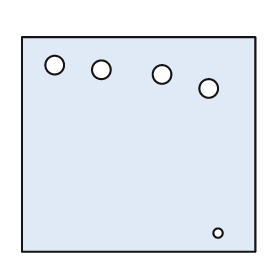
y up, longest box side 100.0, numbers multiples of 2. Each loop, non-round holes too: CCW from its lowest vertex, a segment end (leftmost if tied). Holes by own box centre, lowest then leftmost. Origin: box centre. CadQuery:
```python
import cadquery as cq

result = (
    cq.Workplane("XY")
    .moveTo(-50.0, -46.0)
    .lineTo(50.0, -46.0)
    .lineTo(50.0, 46.0)
    .lineTo(-50.0, 46.0)
    .close()
    .moveTo(34.0, -38.0)
    .circle(2.0)
    .moveTo(30.0, 24.0)
    .circle(4.0)
    .moveTo(10.0, 30.0)
    .circle(4.0)
    .moveTo(-16.0, 32.0)
    .circle(4.0)
    .moveTo(-36.0, 34.0)
    .circle(4.0)
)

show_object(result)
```